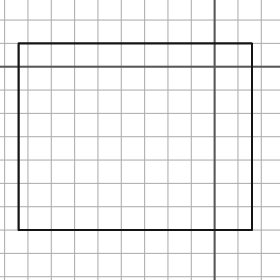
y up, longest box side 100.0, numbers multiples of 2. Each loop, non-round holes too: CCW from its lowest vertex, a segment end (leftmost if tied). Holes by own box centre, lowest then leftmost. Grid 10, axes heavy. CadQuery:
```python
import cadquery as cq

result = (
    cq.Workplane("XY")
    .moveTo(-84.0, -70.0)
    .lineTo(16.0, -70.0)
    .lineTo(16.0, 10.0)
    .lineTo(-84.0, 10.0)
    .close()
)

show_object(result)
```